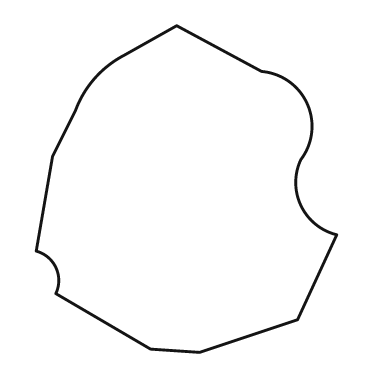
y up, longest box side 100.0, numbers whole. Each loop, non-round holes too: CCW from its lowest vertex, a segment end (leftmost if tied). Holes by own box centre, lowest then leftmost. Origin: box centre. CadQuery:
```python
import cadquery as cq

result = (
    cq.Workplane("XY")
    .moveTo(4.0, -50.0)
    .lineTo(34.0, -40.0)
    .lineTo(46.0, -14.0)
    .threePointArc((35.0, -5.0), (35.0, 9.0))
    .threePointArc((37.0, 26.0), (23.0, 36.0))
    .lineTo(-3.0, 50.0)
    .lineTo(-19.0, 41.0)
    .threePointArc((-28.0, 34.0), (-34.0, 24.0))
    .lineTo(-41.0, 10.0)
    .lineTo(-46.0, -19.0)
    .threePointArc((-40.0, -24.0), (-40.0, -32.0))
    .lineTo(-11.0, -49.0)
    .close()
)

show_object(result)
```